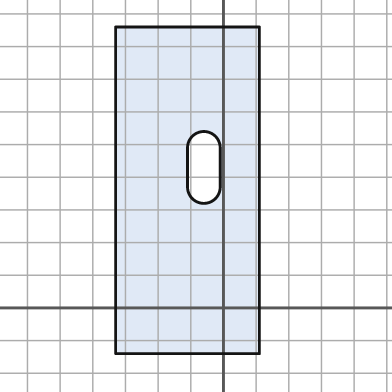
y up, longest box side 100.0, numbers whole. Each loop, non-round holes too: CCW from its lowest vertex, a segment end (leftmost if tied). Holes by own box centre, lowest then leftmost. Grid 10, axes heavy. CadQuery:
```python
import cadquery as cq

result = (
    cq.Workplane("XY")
    .moveTo(-33.0, -14.0)
    .lineTo(11.0, -14.0)
    .lineTo(11.0, 86.0)
    .lineTo(-33.0, 86.0)
    .close()
    .moveTo(-11.0, 37.0)
    .threePointArc((-6.0, 32.0), (-1.0, 37.0))
    .lineTo(-1.0, 49.0)
    .threePointArc((-6.0, 54.0), (-11.0, 49.0))
    .close()
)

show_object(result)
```